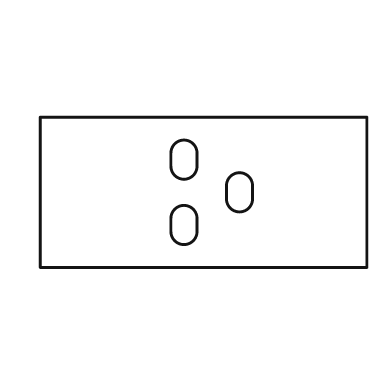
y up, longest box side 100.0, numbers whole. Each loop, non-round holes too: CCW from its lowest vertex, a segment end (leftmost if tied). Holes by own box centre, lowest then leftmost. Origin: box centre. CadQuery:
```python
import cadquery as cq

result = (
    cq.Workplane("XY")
    .moveTo(-50.0, -23.0)
    .lineTo(50.0, -23.0)
    .lineTo(50.0, 23.0)
    .lineTo(-50.0, 23.0)
    .close()
    .moveTo(-10.0, -12.0)
    .threePointArc((-6.0, -16.0), (-2.0, -12.0))
    .lineTo(-2.0, -8.0)
    .threePointArc((-6.0, -4.0), (-10.0, -8.0))
    .close()
    .moveTo(7.0, -2.0)
    .threePointArc((11.0, -6.0), (15.0, -2.0))
    .lineTo(15.0, 2.0)
    .threePointArc((11.0, 6.0), (7.0, 2.0))
    .close()
    .moveTo(-10.0, 8.0)
    .threePointArc((-6.0, 4.0), (-2.0, 8.0))
    .lineTo(-2.0, 12.0)
    .threePointArc((-6.0, 16.0), (-10.0, 12.0))
    .close()
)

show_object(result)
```